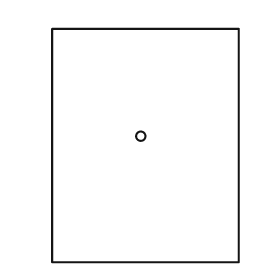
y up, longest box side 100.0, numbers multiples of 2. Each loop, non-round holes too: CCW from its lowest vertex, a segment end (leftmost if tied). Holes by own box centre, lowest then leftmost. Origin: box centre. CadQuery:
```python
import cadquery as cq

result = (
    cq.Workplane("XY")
    .moveTo(-40.0, -50.0)
    .lineTo(40.0, -50.0)
    .lineTo(40.0, 50.0)
    .lineTo(-40.0, 50.0)
    .close()
    .moveTo(-2.0, 4.0)
    .circle(2.0)
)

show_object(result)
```